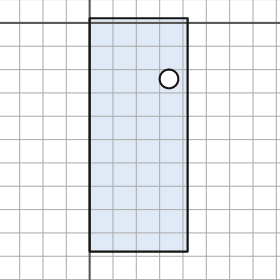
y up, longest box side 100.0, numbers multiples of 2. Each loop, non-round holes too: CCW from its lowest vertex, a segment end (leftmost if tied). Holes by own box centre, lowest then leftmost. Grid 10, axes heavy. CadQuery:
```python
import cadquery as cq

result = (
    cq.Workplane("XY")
    .moveTo(0.0, -98.0)
    .lineTo(42.0, -98.0)
    .lineTo(42.0, 2.0)
    .lineTo(0.0, 2.0)
    .close()
    .moveTo(34.0, -24.0)
    .circle(4.0)
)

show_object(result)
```